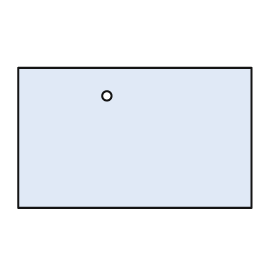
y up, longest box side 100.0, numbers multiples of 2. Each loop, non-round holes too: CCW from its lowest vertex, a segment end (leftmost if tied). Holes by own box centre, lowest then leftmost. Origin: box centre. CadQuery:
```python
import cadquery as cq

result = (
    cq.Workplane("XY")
    .moveTo(-50.0, -30.0)
    .lineTo(50.0, -30.0)
    .lineTo(50.0, 30.0)
    .lineTo(-50.0, 30.0)
    .close()
    .moveTo(-12.0, 18.0)
    .circle(2.0)
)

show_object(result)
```